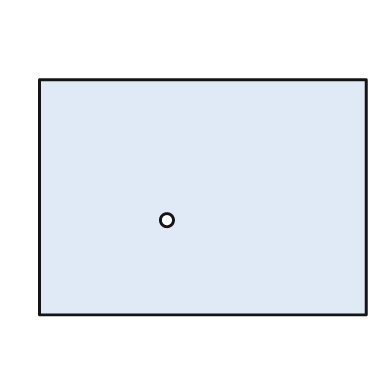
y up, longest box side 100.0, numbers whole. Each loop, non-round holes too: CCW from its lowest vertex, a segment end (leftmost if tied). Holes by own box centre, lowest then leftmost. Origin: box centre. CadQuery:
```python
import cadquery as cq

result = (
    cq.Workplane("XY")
    .moveTo(-50.0, -36.0)
    .lineTo(50.0, -36.0)
    .lineTo(50.0, 36.0)
    .lineTo(-50.0, 36.0)
    .close()
    .moveTo(-11.0, -7.0)
    .circle(2.0)
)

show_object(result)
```